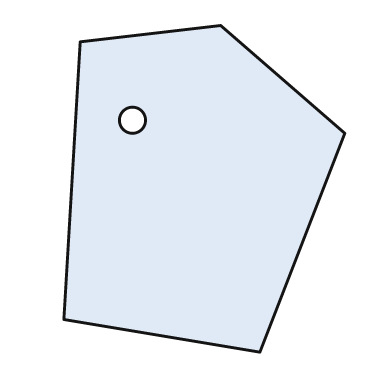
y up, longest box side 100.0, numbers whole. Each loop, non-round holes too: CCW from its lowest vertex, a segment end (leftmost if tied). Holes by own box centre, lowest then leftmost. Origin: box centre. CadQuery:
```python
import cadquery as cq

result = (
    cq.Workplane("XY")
    .moveTo(17.0, -50.0)
    .lineTo(43.0, 17.0)
    .lineTo(5.0, 50.0)
    .lineTo(-38.0, 45.0)
    .lineTo(-43.0, -40.0)
    .close()
    .moveTo(-22.0, 21.0)
    .circle(4.0)
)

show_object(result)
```